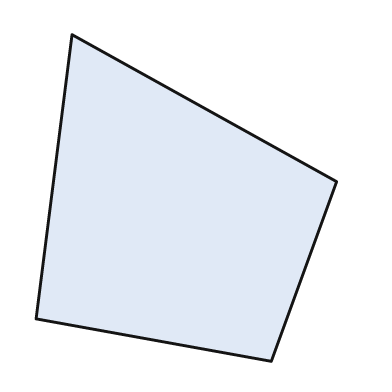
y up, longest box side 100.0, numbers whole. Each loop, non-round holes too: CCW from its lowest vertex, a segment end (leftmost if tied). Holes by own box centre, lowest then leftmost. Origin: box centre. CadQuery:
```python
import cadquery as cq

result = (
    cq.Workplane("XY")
    .moveTo(26.0, -50.0)
    .lineTo(46.0, 5.0)
    .lineTo(-35.0, 50.0)
    .lineTo(-46.0, -37.0)
    .close()
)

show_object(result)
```